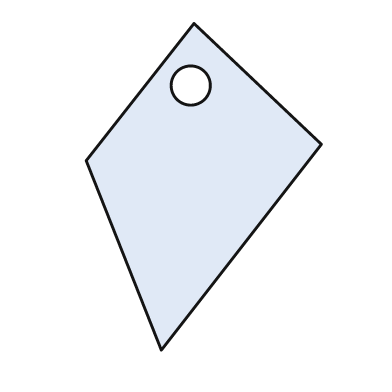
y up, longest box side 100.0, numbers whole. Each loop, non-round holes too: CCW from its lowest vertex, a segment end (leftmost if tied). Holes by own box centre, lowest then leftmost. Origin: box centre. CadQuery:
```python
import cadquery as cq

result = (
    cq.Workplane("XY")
    .moveTo(-13.0, -50.0)
    .lineTo(36.0, 13.0)
    .lineTo(-3.0, 50.0)
    .lineTo(-36.0, 8.0)
    .close()
    .moveTo(-4.0, 31.0)
    .circle(6.0)
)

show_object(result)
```